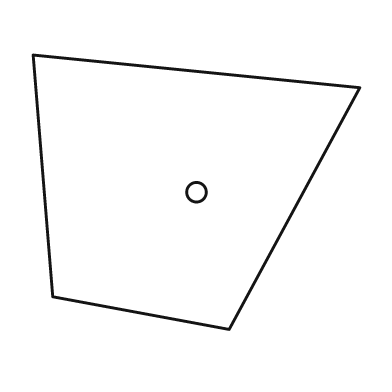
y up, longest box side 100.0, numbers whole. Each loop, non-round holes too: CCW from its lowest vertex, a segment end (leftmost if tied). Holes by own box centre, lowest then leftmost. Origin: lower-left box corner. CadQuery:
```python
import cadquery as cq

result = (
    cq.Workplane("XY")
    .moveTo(60.0, 0.0)
    .lineTo(100.0, 74.0)
    .lineTo(0.0, 84.0)
    .lineTo(6.0, 10.0)
    .close()
    .moveTo(50.0, 42.0)
    .circle(3.0)
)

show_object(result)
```